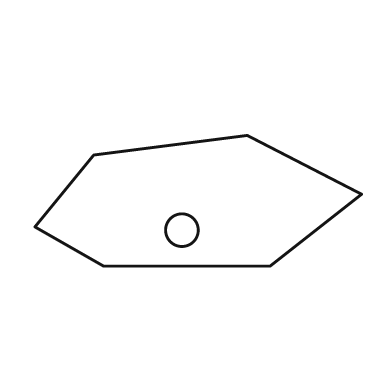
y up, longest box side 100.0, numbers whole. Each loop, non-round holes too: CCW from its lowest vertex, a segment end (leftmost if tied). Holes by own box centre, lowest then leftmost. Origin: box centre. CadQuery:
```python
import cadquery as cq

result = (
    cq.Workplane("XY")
    .moveTo(-29.0, -20.0)
    .lineTo(22.0, -20.0)
    .lineTo(50.0, 2.0)
    .lineTo(15.0, 20.0)
    .lineTo(-32.0, 14.0)
    .lineTo(-50.0, -8.0)
    .close()
    .moveTo(-5.0, -9.0)
    .circle(5.0)
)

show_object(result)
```